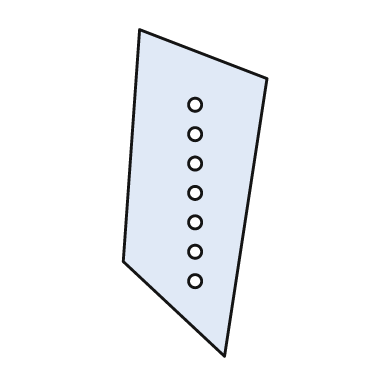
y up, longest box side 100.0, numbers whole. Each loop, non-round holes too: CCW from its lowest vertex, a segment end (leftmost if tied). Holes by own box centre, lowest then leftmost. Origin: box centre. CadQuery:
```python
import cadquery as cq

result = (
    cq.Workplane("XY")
    .moveTo(9.0, -50.0)
    .lineTo(22.0, 35.0)
    .lineTo(-17.0, 50.0)
    .lineTo(-22.0, -21.0)
    .close()
    .moveTo(0.0, -27.0)
    .circle(2.0)
    .moveTo(0.0, -18.0)
    .circle(2.0)
    .moveTo(0.0, -9.0)
    .circle(2.0)
    .moveTo(0.0, 0.0)
    .circle(2.0)
    .moveTo(0.0, 9.0)
    .circle(2.0)
    .moveTo(0.0, 18.0)
    .circle(2.0)
    .moveTo(0.0, 27.0)
    .circle(2.0)
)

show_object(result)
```